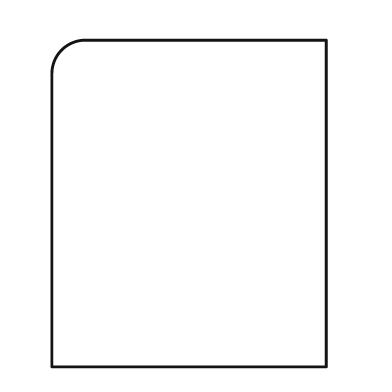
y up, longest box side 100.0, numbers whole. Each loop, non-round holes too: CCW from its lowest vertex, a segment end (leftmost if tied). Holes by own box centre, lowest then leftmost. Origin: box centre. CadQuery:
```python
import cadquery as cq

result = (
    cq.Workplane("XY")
    .moveTo(-42.0, -50.0)
    .lineTo(42.0, -50.0)
    .lineTo(42.0, 50.0)
    .lineTo(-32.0, 50.0)
    .threePointArc((-39.0, 47.0), (-42.0, 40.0))
    .close()
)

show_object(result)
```